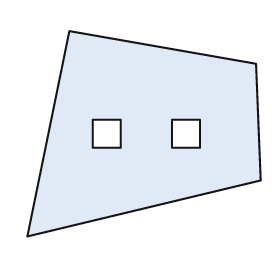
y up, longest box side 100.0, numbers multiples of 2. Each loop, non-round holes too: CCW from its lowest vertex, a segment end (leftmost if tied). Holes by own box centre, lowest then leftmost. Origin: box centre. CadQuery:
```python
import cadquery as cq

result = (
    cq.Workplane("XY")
    .moveTo(-50.0, -44.0)
    .lineTo(50.0, -20.0)
    .lineTo(48.0, 30.0)
    .lineTo(-32.0, 44.0)
    .close()
    .moveTo(-22.0, -6.0)
    .lineTo(-10.0, -6.0)
    .lineTo(-10.0, 6.0)
    .lineTo(-22.0, 6.0)
    .close()
    .moveTo(12.0, -6.0)
    .lineTo(24.0, -6.0)
    .lineTo(24.0, 6.0)
    .lineTo(12.0, 6.0)
    .close()
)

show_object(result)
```